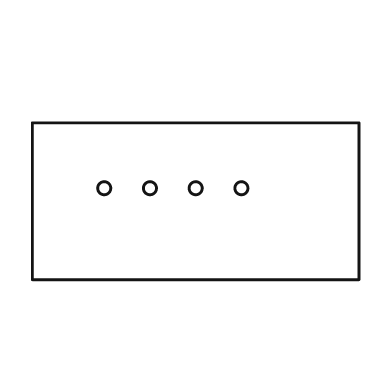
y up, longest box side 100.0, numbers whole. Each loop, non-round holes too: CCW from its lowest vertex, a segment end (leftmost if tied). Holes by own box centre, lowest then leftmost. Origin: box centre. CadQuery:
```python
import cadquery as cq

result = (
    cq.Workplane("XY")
    .moveTo(-50.0, -24.0)
    .lineTo(50.0, -24.0)
    .lineTo(50.0, 24.0)
    .lineTo(-50.0, 24.0)
    .close()
    .moveTo(-28.0, 4.0)
    .circle(2.0)
    .moveTo(-14.0, 4.0)
    .circle(2.0)
    .moveTo(0.0, 4.0)
    .circle(2.0)
    .moveTo(14.0, 4.0)
    .circle(2.0)
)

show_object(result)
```